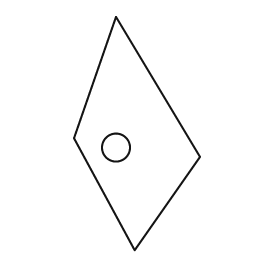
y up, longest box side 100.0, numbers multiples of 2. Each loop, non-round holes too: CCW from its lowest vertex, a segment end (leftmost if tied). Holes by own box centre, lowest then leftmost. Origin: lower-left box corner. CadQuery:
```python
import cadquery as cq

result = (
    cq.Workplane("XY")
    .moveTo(26.0, 0.0)
    .lineTo(54.0, 40.0)
    .lineTo(18.0, 100.0)
    .lineTo(0.0, 48.0)
    .close()
    .moveTo(18.0, 44.0)
    .circle(6.0)
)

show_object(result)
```